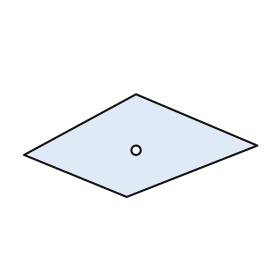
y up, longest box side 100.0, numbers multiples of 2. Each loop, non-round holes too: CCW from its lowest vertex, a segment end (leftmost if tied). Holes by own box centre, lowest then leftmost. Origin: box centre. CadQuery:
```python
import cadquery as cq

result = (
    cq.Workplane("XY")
    .moveTo(-6.0, -22.0)
    .lineTo(50.0, 0.0)
    .lineTo(-2.0, 22.0)
    .lineTo(-50.0, -4.0)
    .close()
    .moveTo(-2.0, -2.0)
    .circle(2.0)
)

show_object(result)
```